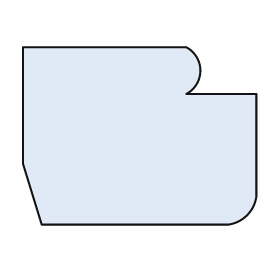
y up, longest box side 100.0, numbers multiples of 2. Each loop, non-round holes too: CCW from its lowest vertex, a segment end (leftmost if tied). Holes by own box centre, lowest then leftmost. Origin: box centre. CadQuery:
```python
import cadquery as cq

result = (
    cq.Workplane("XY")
    .moveTo(-42.0, -38.0)
    .lineTo(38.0, -38.0)
    .threePointArc((46.0, -34.0), (50.0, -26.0))
    .lineTo(50.0, 18.0)
    .lineTo(20.0, 18.0)
    .threePointArc((26.0, 28.0), (20.0, 38.0))
    .lineTo(-50.0, 38.0)
    .lineTo(-50.0, -12.0)
    .close()
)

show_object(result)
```